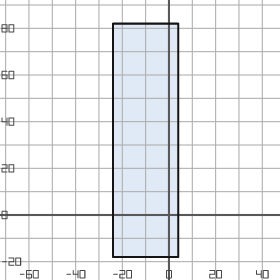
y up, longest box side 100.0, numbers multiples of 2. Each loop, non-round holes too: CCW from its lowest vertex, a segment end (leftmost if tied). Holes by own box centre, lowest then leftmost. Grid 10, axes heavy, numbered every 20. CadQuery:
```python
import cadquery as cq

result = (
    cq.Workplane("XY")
    .moveTo(-24.0, -18.0)
    .lineTo(4.0, -18.0)
    .lineTo(4.0, 82.0)
    .lineTo(-24.0, 82.0)
    .close()
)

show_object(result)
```